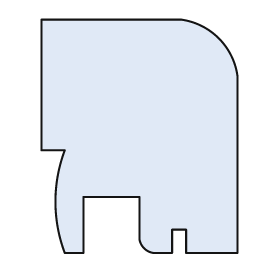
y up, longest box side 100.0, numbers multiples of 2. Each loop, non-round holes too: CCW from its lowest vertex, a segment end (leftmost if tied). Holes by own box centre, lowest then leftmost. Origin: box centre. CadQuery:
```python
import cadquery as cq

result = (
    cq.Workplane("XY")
    .moveTo(-32.0, -50.0)
    .lineTo(-24.0, -50.0)
    .lineTo(-24.0, -26.0)
    .lineTo(0.0, -26.0)
    .lineTo(0.0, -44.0)
    .threePointArc((2.0, -48.0), (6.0, -50.0))
    .lineTo(14.0, -50.0)
    .lineTo(14.0, -40.0)
    .lineTo(20.0, -40.0)
    .lineTo(20.0, -50.0)
    .lineTo(42.0, -50.0)
    .lineTo(42.0, 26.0)
    .threePointArc((34.0, 42.0), (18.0, 50.0))
    .lineTo(-42.0, 50.0)
    .lineTo(-42.0, -6.0)
    .lineTo(-32.0, -6.0)
    .threePointArc((-36.0, -28.0), (-32.0, -50.0))
    .close()
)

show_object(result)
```